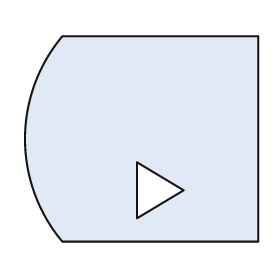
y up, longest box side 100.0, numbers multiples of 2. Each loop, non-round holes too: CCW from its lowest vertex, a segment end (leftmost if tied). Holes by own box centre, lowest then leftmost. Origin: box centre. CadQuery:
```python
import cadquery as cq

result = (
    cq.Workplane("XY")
    .moveTo(-34.0, -44.0)
    .lineTo(50.0, -44.0)
    .lineTo(50.0, 44.0)
    .lineTo(-34.0, 44.0)
    .threePointArc((-50.0, 0.0), (-34.0, -44.0))
    .close()
    .moveTo(-2.0, -34.0)
    .lineTo(18.0, -22.0)
    .lineTo(-2.0, -10.0)
    .close()
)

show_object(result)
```